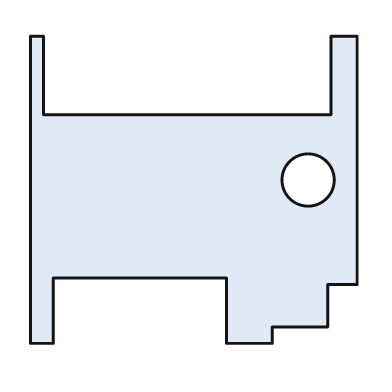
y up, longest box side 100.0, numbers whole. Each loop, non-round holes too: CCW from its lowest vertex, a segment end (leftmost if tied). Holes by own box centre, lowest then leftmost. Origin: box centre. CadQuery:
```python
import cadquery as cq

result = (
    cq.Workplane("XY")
    .moveTo(-50.0, -47.0)
    .lineTo(-43.0, -47.0)
    .lineTo(-43.0, -27.0)
    .lineTo(10.0, -27.0)
    .lineTo(10.0, -47.0)
    .lineTo(24.0, -47.0)
    .lineTo(24.0, -42.0)
    .lineTo(41.0, -42.0)
    .lineTo(41.0, -29.0)
    .lineTo(50.0, -29.0)
    .lineTo(50.0, 47.0)
    .lineTo(42.0, 47.0)
    .lineTo(42.0, 23.0)
    .lineTo(-46.0, 23.0)
    .lineTo(-46.0, 47.0)
    .lineTo(-50.0, 47.0)
    .close()
    .moveTo(35.0, 3.0)
    .circle(8.0)
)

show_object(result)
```